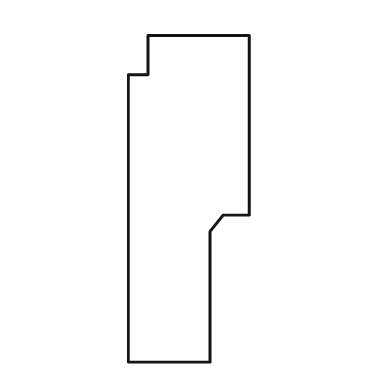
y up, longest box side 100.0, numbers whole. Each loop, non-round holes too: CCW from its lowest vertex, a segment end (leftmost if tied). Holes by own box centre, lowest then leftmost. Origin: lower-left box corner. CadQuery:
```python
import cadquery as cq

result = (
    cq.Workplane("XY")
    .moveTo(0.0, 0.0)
    .lineTo(25.0, 0.0)
    .lineTo(25.0, 40.0)
    .lineTo(29.0, 45.0)
    .lineTo(37.0, 45.0)
    .lineTo(37.0, 100.0)
    .lineTo(6.0, 100.0)
    .lineTo(6.0, 88.0)
    .lineTo(0.0, 88.0)
    .close()
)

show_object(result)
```